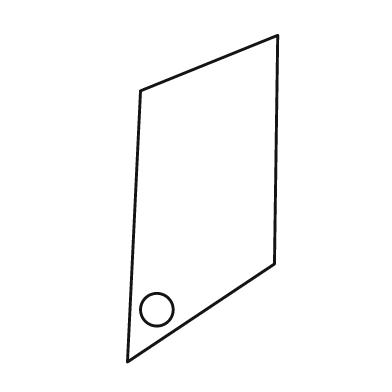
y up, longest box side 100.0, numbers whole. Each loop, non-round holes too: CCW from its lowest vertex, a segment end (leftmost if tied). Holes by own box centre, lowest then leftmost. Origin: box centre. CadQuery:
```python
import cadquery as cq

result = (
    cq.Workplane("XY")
    .moveTo(-23.0, -50.0)
    .lineTo(22.0, -20.0)
    .lineTo(23.0, 50.0)
    .lineTo(-19.0, 33.0)
    .close()
    .moveTo(-14.0, -34.0)
    .circle(5.0)
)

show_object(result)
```